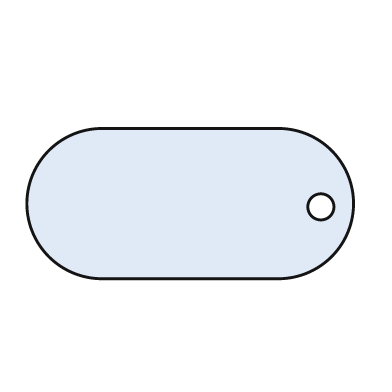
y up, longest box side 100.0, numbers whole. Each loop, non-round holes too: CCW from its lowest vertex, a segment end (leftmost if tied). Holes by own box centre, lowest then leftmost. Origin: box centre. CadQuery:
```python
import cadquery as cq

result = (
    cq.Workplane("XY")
    .moveTo(-27.0, -23.0)
    .lineTo(27.0, -23.0)
    .threePointArc((50.0, 0.0), (27.0, 23.0))
    .lineTo(-27.0, 23.0)
    .threePointArc((-50.0, 0.0), (-27.0, -23.0))
    .close()
    .moveTo(40.0, -1.0)
    .circle(4.0)
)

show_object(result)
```